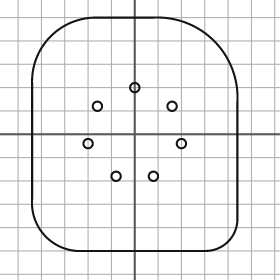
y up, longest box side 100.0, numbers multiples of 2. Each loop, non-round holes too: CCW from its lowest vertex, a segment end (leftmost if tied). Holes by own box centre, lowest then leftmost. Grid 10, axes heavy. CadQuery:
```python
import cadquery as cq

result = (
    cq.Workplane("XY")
    .moveTo(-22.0, -50.0)
    .lineTo(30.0, -50.0)
    .threePointArc((40.0, -46.0), (44.0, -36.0))
    .lineTo(44.0, 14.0)
    .threePointArc((34.0, 40.0), (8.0, 50.0))
    .lineTo(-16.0, 50.0)
    .threePointArc((-36.0, 42.0), (-44.0, 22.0))
    .lineTo(-44.0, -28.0)
    .threePointArc((-38.0, -44.0), (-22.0, -50.0))
    .close()
    .moveTo(-8.0, -18.0)
    .circle(2.0)
    .moveTo(8.0, -18.0)
    .circle(2.0)
    .moveTo(-20.0, -4.0)
    .circle(2.0)
    .moveTo(20.0, -4.0)
    .circle(2.0)
    .moveTo(-16.0, 12.0)
    .circle(2.0)
    .moveTo(16.0, 12.0)
    .circle(2.0)
    .moveTo(0.0, 20.0)
    .circle(2.0)
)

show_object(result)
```